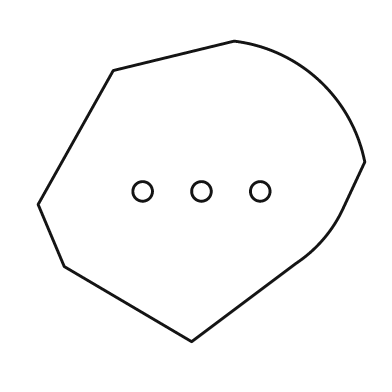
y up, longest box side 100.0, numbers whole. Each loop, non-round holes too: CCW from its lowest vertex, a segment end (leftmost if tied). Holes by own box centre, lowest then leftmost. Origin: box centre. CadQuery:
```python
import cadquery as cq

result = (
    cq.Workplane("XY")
    .moveTo(-3.0, -46.0)
    .lineTo(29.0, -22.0)
    .threePointArc((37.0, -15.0), (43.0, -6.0))
    .lineTo(50.0, 9.0)
    .threePointArc((36.0, 34.0), (10.0, 46.0))
    .lineTo(-27.0, 37.0)
    .lineTo(-50.0, -4.0)
    .lineTo(-42.0, -23.0)
    .close()
    .moveTo(-18.0, 0.0)
    .circle(3.0)
    .moveTo(0.0, 0.0)
    .circle(3.0)
    .moveTo(18.0, 0.0)
    .circle(3.0)
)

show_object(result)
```